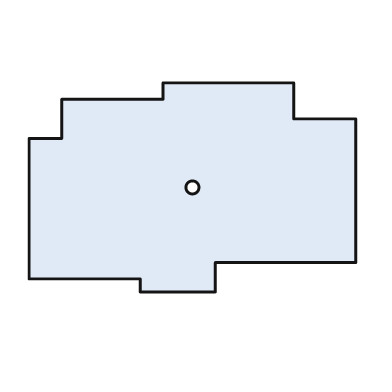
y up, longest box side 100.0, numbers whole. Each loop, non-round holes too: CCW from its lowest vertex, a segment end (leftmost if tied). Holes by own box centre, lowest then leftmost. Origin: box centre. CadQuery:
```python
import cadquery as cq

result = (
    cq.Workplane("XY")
    .moveTo(-16.0, -32.0)
    .lineTo(7.0, -32.0)
    .lineTo(7.0, -23.0)
    .lineTo(50.0, -23.0)
    .lineTo(50.0, 21.0)
    .lineTo(31.0, 21.0)
    .lineTo(31.0, 32.0)
    .lineTo(-9.0, 32.0)
    .lineTo(-9.0, 27.0)
    .lineTo(-40.0, 27.0)
    .lineTo(-40.0, 15.0)
    .lineTo(-50.0, 15.0)
    .lineTo(-50.0, -28.0)
    .lineTo(-16.0, -28.0)
    .close()
    .moveTo(0.0, 0.0)
    .circle(2.0)
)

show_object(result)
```